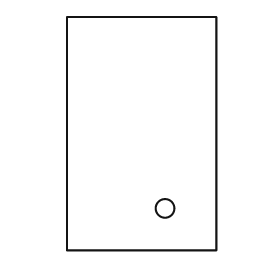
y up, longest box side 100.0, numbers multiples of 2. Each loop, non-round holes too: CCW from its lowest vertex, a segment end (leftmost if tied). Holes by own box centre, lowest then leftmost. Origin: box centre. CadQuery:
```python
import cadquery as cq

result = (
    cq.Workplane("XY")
    .moveTo(-32.0, -50.0)
    .lineTo(32.0, -50.0)
    .lineTo(32.0, 50.0)
    .lineTo(-32.0, 50.0)
    .close()
    .moveTo(10.0, -32.0)
    .circle(4.0)
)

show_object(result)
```